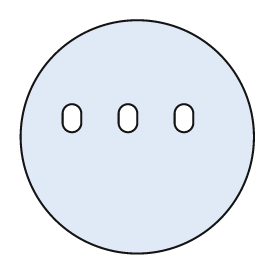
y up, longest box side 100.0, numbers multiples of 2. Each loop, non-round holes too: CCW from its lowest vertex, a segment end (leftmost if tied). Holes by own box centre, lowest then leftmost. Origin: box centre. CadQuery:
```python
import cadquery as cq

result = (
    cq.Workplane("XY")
    .moveTo(0.0, 0.0)
    .circle(50.0)
    .moveTo(-32.0, 6.0)
    .threePointArc((-28.0, 2.0), (-24.0, 6.0))
    .lineTo(-24.0, 10.0)
    .threePointArc((-28.0, 14.0), (-32.0, 10.0))
    .close()
    .moveTo(-8.0, 6.0)
    .threePointArc((-4.0, 2.0), (0.0, 6.0))
    .lineTo(0.0, 10.0)
    .threePointArc((-4.0, 14.0), (-8.0, 10.0))
    .close()
    .moveTo(16.0, 6.0)
    .threePointArc((20.0, 2.0), (24.0, 6.0))
    .lineTo(24.0, 10.0)
    .threePointArc((20.0, 14.0), (16.0, 10.0))
    .close()
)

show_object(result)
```